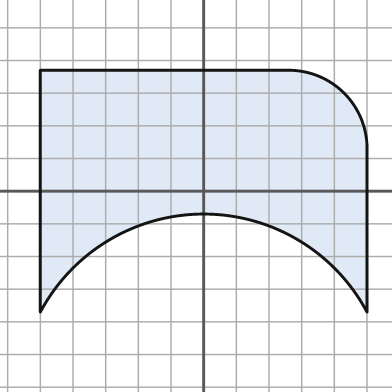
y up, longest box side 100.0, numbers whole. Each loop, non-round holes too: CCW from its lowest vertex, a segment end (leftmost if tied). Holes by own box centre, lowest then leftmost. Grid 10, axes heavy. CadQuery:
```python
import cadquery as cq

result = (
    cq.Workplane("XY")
    .moveTo(-50.0, -37.0)
    .threePointArc((0.0, -7.0), (50.0, -37.0))
    .lineTo(50.0, 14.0)
    .threePointArc((43.0, 30.0), (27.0, 37.0))
    .lineTo(-50.0, 37.0)
    .close()
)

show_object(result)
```